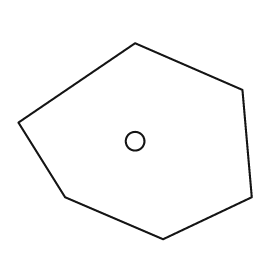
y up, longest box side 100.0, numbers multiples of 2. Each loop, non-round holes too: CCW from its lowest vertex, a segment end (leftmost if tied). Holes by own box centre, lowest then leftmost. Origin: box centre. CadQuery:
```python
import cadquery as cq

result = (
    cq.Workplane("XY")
    .moveTo(12.0, -42.0)
    .lineTo(50.0, -24.0)
    .lineTo(46.0, 22.0)
    .lineTo(0.0, 42.0)
    .lineTo(-50.0, 8.0)
    .lineTo(-30.0, -24.0)
    .close()
    .moveTo(0.0, 0.0)
    .circle(4.0)
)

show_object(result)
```